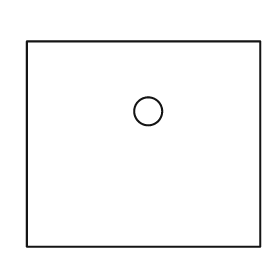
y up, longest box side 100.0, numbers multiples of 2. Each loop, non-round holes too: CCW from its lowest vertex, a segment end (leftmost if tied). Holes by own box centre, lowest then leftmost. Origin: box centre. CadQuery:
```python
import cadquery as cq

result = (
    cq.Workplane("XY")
    .moveTo(-50.0, -44.0)
    .lineTo(50.0, -44.0)
    .lineTo(50.0, 44.0)
    .lineTo(-50.0, 44.0)
    .close()
    .moveTo(2.0, 14.0)
    .circle(6.0)
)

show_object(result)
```